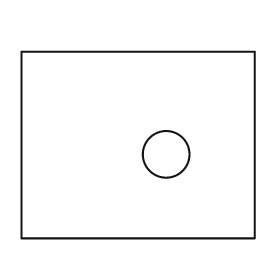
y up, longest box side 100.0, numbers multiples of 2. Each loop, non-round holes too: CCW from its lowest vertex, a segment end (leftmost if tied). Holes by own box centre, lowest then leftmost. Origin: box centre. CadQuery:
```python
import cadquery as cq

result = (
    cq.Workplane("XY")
    .moveTo(-50.0, -40.0)
    .lineTo(50.0, -40.0)
    .lineTo(50.0, 40.0)
    .lineTo(-50.0, 40.0)
    .close()
    .moveTo(12.0, -4.0)
    .circle(10.0)
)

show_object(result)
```